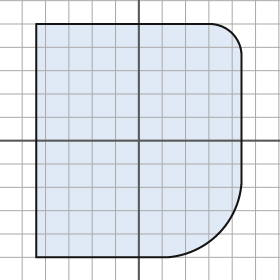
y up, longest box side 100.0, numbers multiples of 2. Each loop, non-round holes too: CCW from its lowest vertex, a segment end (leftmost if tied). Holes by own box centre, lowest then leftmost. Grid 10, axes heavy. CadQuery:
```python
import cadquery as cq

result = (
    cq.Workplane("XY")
    .moveTo(-44.0, -50.0)
    .lineTo(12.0, -50.0)
    .threePointArc((34.0, -40.0), (44.0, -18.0))
    .lineTo(44.0, 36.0)
    .threePointArc((40.0, 46.0), (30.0, 50.0))
    .lineTo(-44.0, 50.0)
    .close()
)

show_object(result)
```